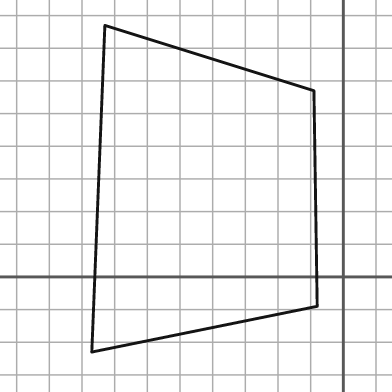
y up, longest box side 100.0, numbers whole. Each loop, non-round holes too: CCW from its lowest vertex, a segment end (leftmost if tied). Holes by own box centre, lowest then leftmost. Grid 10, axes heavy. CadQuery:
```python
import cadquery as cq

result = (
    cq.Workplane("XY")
    .moveTo(-77.0, -23.0)
    .lineTo(-8.0, -9.0)
    .lineTo(-9.0, 57.0)
    .lineTo(-73.0, 77.0)
    .close()
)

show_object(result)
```